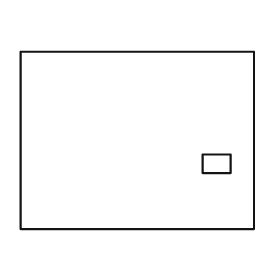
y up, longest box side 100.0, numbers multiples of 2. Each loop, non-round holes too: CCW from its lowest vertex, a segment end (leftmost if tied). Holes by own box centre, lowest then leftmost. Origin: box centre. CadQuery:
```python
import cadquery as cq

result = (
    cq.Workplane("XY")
    .moveTo(-50.0, -38.0)
    .lineTo(50.0, -38.0)
    .lineTo(50.0, 38.0)
    .lineTo(-50.0, 38.0)
    .close()
    .moveTo(28.0, -14.0)
    .lineTo(40.0, -14.0)
    .lineTo(40.0, -6.0)
    .lineTo(28.0, -6.0)
    .close()
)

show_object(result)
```